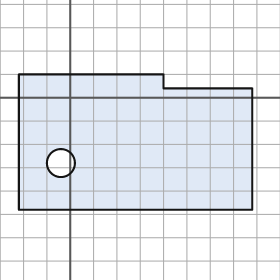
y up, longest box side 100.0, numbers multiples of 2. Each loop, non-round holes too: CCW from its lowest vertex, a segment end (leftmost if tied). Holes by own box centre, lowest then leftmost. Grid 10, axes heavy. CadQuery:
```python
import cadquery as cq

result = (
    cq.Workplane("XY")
    .moveTo(-22.0, -48.0)
    .lineTo(78.0, -48.0)
    .lineTo(78.0, 4.0)
    .lineTo(40.0, 4.0)
    .lineTo(40.0, 10.0)
    .lineTo(-22.0, 10.0)
    .close()
    .moveTo(-4.0, -28.0)
    .circle(6.0)
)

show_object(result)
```